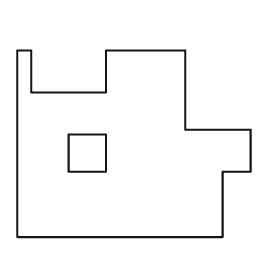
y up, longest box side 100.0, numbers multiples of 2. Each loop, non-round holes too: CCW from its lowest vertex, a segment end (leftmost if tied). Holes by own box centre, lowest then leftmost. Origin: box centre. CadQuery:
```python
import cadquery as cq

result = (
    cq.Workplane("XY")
    .moveTo(-50.0, -40.0)
    .lineTo(38.0, -40.0)
    .lineTo(38.0, -12.0)
    .lineTo(50.0, -12.0)
    .lineTo(50.0, 6.0)
    .lineTo(22.0, 6.0)
    .lineTo(22.0, 40.0)
    .lineTo(-12.0, 40.0)
    .lineTo(-12.0, 22.0)
    .lineTo(-44.0, 22.0)
    .lineTo(-44.0, 40.0)
    .lineTo(-50.0, 40.0)
    .close()
    .moveTo(-28.0, -12.0)
    .lineTo(-12.0, -12.0)
    .lineTo(-12.0, 4.0)
    .lineTo(-28.0, 4.0)
    .close()
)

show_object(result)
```